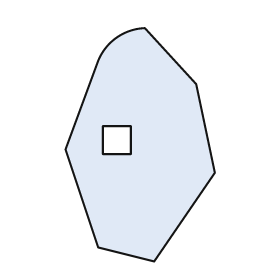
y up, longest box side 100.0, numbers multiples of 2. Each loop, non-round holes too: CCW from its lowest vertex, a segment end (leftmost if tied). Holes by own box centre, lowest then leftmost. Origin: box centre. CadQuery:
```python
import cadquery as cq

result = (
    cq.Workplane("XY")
    .moveTo(6.0, -50.0)
    .lineTo(32.0, -12.0)
    .lineTo(24.0, 26.0)
    .lineTo(2.0, 50.0)
    .threePointArc((-10.0, 46.0), (-18.0, 36.0))
    .lineTo(-32.0, -2.0)
    .lineTo(-18.0, -44.0)
    .close()
    .moveTo(-16.0, -4.0)
    .lineTo(-4.0, -4.0)
    .lineTo(-4.0, 8.0)
    .lineTo(-16.0, 8.0)
    .close()
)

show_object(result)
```